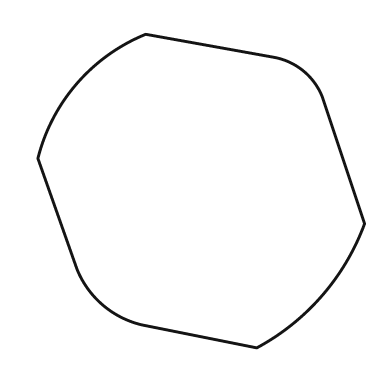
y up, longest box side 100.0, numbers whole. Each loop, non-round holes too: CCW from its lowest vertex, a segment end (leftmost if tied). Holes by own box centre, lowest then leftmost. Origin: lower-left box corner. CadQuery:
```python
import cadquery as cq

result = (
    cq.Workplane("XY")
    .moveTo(67.0, 0.0)
    .threePointArc((87.0, 16.0), (100.0, 38.0))
    .lineTo(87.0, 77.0)
    .threePointArc((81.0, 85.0), (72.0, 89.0))
    .lineTo(33.0, 96.0)
    .threePointArc((12.0, 81.0), (0.0, 58.0))
    .lineTo(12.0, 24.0)
    .threePointArc((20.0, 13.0), (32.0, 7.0))
    .close()
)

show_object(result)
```